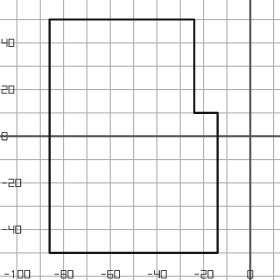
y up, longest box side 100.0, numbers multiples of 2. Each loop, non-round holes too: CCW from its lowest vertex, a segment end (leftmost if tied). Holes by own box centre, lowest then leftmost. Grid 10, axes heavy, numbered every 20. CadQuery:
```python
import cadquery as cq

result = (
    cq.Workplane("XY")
    .moveTo(-86.0, -50.0)
    .lineTo(-14.0, -50.0)
    .lineTo(-14.0, 10.0)
    .lineTo(-24.0, 10.0)
    .lineTo(-24.0, 50.0)
    .lineTo(-86.0, 50.0)
    .close()
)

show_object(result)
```